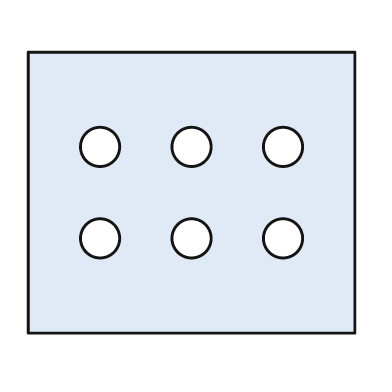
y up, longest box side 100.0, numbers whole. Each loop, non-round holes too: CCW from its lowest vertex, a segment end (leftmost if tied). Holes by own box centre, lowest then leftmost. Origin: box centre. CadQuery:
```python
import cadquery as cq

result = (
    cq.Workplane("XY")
    .moveTo(-50.0, -43.0)
    .lineTo(50.0, -43.0)
    .lineTo(50.0, 43.0)
    .lineTo(-50.0, 43.0)
    .close()
    .moveTo(-28.0, -14.0)
    .circle(6.0)
    .moveTo(0.0, -14.0)
    .circle(6.0)
    .moveTo(28.0, -14.0)
    .circle(6.0)
    .moveTo(-28.0, 14.0)
    .circle(6.0)
    .moveTo(0.0, 14.0)
    .circle(6.0)
    .moveTo(28.0, 14.0)
    .circle(6.0)
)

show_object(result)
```